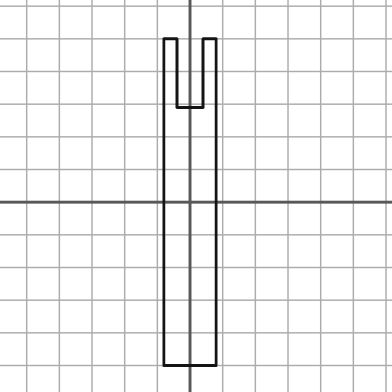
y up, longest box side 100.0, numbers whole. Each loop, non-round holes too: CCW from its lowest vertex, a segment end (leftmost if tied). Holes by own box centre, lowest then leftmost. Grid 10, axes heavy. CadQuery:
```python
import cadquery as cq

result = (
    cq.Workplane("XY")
    .moveTo(-8.0, -50.0)
    .lineTo(8.0, -50.0)
    .lineTo(8.0, 50.0)
    .lineTo(4.0, 50.0)
    .lineTo(4.0, 29.0)
    .lineTo(-4.0, 29.0)
    .lineTo(-4.0, 50.0)
    .lineTo(-8.0, 50.0)
    .close()
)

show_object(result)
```